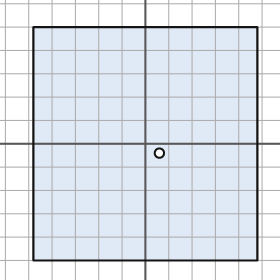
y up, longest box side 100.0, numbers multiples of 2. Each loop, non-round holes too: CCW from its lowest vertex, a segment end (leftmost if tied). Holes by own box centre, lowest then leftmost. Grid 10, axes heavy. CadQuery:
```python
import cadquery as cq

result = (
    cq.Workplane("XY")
    .moveTo(-48.0, -50.0)
    .lineTo(48.0, -50.0)
    .lineTo(48.0, 50.0)
    .lineTo(-48.0, 50.0)
    .close()
    .moveTo(6.0, -4.0)
    .circle(2.0)
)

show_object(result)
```